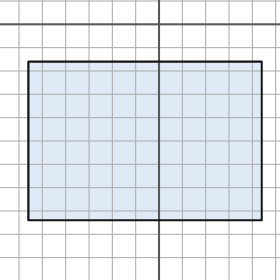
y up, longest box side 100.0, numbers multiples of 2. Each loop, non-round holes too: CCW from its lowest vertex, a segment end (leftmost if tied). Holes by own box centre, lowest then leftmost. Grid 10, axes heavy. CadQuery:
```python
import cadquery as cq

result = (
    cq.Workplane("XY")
    .moveTo(-56.0, -84.0)
    .lineTo(44.0, -84.0)
    .lineTo(44.0, -16.0)
    .lineTo(-56.0, -16.0)
    .close()
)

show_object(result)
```